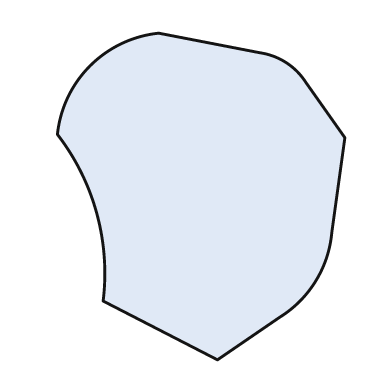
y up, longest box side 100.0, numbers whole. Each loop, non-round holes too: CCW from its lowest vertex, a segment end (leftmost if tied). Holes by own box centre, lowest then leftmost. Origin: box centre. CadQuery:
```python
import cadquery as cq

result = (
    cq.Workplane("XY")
    .moveTo(5.0, -50.0)
    .lineTo(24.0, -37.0)
    .threePointArc((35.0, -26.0), (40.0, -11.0))
    .lineTo(44.0, 18.0)
    .lineTo(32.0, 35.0)
    .threePointArc((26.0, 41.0), (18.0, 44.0))
    .lineTo(-13.0, 50.0)
    .threePointArc((-34.0, 40.0), (-44.0, 19.0))
    .threePointArc((-32.0, -5.0), (-30.0, -32.0))
    .close()
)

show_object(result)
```